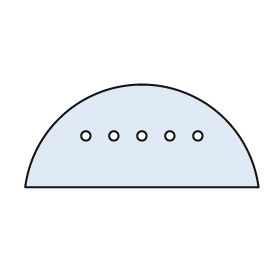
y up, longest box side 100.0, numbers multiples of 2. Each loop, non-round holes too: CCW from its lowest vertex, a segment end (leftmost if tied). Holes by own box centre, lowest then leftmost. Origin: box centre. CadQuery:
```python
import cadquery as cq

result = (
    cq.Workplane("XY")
    .moveTo(-50.0, -22.0)
    .lineTo(50.0, -22.0)
    .threePointArc((0.0, 22.0), (-50.0, -22.0))
    .close()
    .moveTo(-24.0, 0.0)
    .circle(2.0)
    .moveTo(-12.0, 0.0)
    .circle(2.0)
    .moveTo(0.0, 0.0)
    .circle(2.0)
    .moveTo(12.0, 0.0)
    .circle(2.0)
    .moveTo(24.0, 0.0)
    .circle(2.0)
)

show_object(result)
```